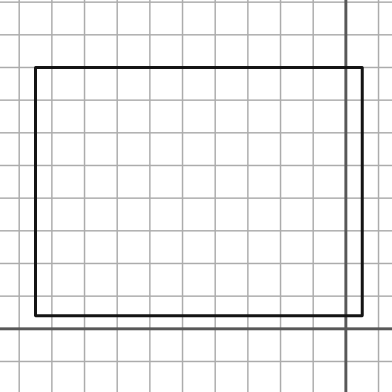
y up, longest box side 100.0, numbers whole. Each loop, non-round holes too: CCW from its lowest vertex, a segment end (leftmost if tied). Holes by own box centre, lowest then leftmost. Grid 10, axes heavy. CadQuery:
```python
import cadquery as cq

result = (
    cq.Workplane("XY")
    .moveTo(-95.0, 4.0)
    .lineTo(5.0, 4.0)
    .lineTo(5.0, 80.0)
    .lineTo(-95.0, 80.0)
    .close()
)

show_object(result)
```